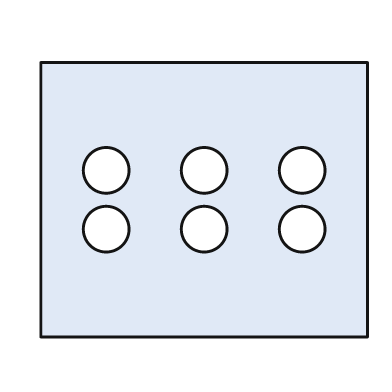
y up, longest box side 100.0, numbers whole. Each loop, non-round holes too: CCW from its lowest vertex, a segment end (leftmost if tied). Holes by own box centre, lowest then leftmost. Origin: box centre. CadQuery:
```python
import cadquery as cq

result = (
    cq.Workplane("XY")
    .moveTo(-50.0, -42.0)
    .lineTo(50.0, -42.0)
    .lineTo(50.0, 42.0)
    .lineTo(-50.0, 42.0)
    .close()
    .moveTo(-30.0, -9.0)
    .circle(7.0)
    .moveTo(0.0, -9.0)
    .circle(7.0)
    .moveTo(30.0, -9.0)
    .circle(7.0)
    .moveTo(-30.0, 9.0)
    .circle(7.0)
    .moveTo(0.0, 9.0)
    .circle(7.0)
    .moveTo(30.0, 9.0)
    .circle(7.0)
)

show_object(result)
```